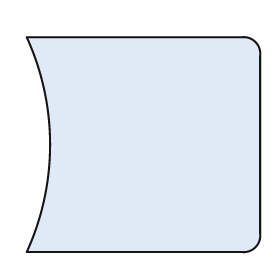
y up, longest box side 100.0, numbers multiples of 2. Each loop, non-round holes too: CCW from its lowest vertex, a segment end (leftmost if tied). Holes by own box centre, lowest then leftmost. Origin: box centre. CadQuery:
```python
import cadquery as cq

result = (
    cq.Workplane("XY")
    .moveTo(-50.0, -46.0)
    .lineTo(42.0, -46.0)
    .threePointArc((48.0, -44.0), (50.0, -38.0))
    .lineTo(50.0, 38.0)
    .threePointArc((48.0, 44.0), (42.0, 46.0))
    .lineTo(-50.0, 46.0)
    .threePointArc((-40.0, 0.0), (-50.0, -46.0))
    .close()
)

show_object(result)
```